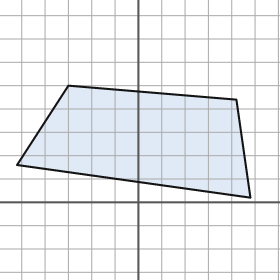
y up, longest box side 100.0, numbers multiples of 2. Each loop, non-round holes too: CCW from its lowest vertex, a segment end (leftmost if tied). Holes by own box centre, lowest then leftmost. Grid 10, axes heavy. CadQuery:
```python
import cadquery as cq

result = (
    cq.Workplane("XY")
    .moveTo(48.0, 2.0)
    .lineTo(42.0, 44.0)
    .lineTo(-30.0, 50.0)
    .lineTo(-52.0, 16.0)
    .close()
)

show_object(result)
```